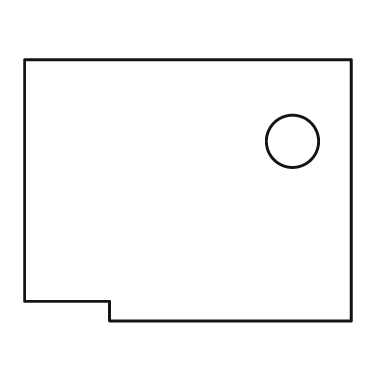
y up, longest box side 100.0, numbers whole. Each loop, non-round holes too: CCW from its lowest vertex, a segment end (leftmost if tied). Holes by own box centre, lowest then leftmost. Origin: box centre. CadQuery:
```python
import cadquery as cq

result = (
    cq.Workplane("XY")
    .moveTo(-24.0, -40.0)
    .lineTo(50.0, -40.0)
    .lineTo(50.0, 40.0)
    .lineTo(-50.0, 40.0)
    .lineTo(-50.0, -34.0)
    .lineTo(-24.0, -34.0)
    .close()
    .moveTo(32.0, 15.0)
    .circle(8.0)
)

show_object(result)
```